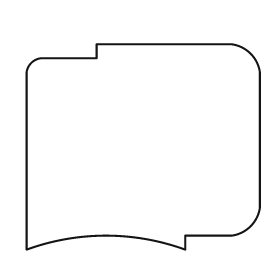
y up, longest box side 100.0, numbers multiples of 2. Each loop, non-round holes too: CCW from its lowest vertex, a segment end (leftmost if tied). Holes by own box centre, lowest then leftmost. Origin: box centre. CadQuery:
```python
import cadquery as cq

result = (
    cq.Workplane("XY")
    .moveTo(-50.0, -44.0)
    .threePointArc((-16.0, -38.0), (18.0, -44.0))
    .lineTo(18.0, -38.0)
    .lineTo(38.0, -38.0)
    .threePointArc((46.0, -34.0), (50.0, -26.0))
    .lineTo(50.0, 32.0)
    .threePointArc((46.0, 40.0), (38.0, 44.0))
    .lineTo(-20.0, 44.0)
    .lineTo(-20.0, 38.0)
    .lineTo(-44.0, 38.0)
    .threePointArc((-48.0, 36.0), (-50.0, 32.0))
    .close()
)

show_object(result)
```